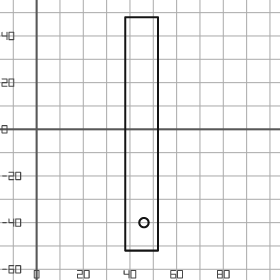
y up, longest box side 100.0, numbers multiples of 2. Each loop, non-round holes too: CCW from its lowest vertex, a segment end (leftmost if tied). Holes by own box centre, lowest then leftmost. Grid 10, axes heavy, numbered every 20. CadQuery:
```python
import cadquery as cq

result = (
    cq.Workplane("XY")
    .moveTo(38.0, -52.0)
    .lineTo(52.0, -52.0)
    .lineTo(52.0, 48.0)
    .lineTo(38.0, 48.0)
    .close()
    .moveTo(46.0, -40.0)
    .circle(2.0)
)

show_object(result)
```